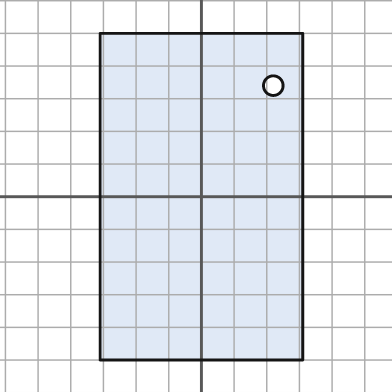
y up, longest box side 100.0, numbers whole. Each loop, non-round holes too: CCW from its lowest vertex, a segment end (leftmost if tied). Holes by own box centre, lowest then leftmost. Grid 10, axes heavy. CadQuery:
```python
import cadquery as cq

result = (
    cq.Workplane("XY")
    .moveTo(-31.0, -50.0)
    .lineTo(31.0, -50.0)
    .lineTo(31.0, 50.0)
    .lineTo(-31.0, 50.0)
    .close()
    .moveTo(22.0, 34.0)
    .circle(3.0)
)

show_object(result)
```